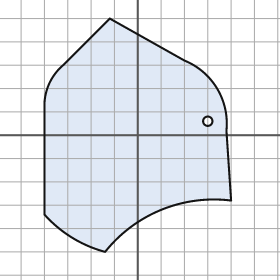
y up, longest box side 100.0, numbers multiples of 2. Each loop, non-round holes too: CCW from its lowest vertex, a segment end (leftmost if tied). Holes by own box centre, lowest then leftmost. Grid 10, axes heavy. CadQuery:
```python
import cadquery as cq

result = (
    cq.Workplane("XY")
    .moveTo(-14.0, -50.0)
    .threePointArc((10.0, -32.0), (40.0, -28.0))
    .lineTo(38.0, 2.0)
    .threePointArc((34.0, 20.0), (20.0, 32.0))
    .lineTo(-12.0, 50.0)
    .lineTo(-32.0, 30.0)
    .threePointArc((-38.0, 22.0), (-40.0, 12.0))
    .lineTo(-40.0, -34.0)
    .threePointArc((-28.0, -44.0), (-14.0, -50.0))
    .close()
    .moveTo(30.0, 6.0)
    .circle(2.0)
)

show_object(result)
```